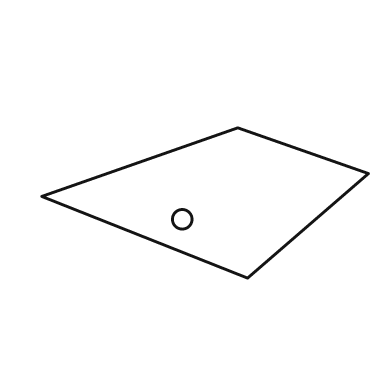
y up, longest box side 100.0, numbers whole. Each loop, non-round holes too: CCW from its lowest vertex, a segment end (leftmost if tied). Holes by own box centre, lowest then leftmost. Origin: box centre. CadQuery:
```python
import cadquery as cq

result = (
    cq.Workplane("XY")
    .moveTo(13.0, -23.0)
    .lineTo(50.0, 9.0)
    .lineTo(10.0, 23.0)
    .lineTo(-50.0, 2.0)
    .close()
    .moveTo(-7.0, -5.0)
    .circle(3.0)
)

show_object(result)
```